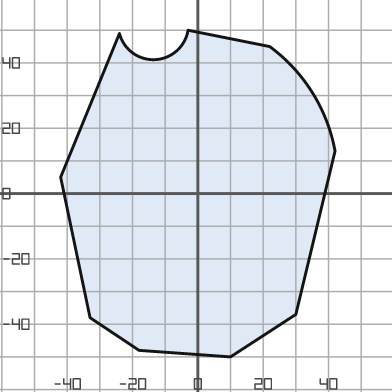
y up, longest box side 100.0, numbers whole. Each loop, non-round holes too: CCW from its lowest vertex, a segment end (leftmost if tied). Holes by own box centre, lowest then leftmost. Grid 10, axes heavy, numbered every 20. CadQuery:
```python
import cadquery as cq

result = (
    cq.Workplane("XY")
    .moveTo(10.0, -50.0)
    .lineTo(30.0, -37.0)
    .lineTo(42.0, 13.0)
    .threePointArc((35.0, 31.0), (22.0, 45.0))
    .lineTo(-3.0, 50.0)
    .threePointArc((-13.0, 41.0), (-24.0, 49.0))
    .lineTo(-42.0, 5.0)
    .lineTo(-33.0, -38.0)
    .lineTo(-18.0, -48.0)
    .close()
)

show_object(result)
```